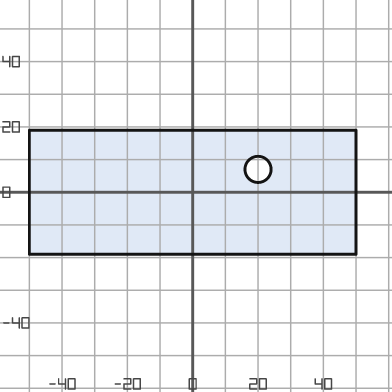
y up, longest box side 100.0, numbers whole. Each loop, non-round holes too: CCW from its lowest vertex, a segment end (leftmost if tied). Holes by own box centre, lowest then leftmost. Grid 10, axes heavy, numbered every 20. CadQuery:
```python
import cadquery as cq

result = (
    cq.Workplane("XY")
    .moveTo(-50.0, -19.0)
    .lineTo(50.0, -19.0)
    .lineTo(50.0, 19.0)
    .lineTo(-50.0, 19.0)
    .close()
    .moveTo(20.0, 7.0)
    .circle(4.0)
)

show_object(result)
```